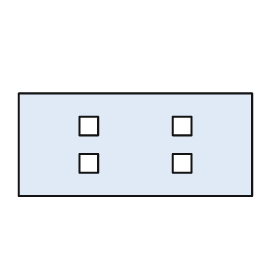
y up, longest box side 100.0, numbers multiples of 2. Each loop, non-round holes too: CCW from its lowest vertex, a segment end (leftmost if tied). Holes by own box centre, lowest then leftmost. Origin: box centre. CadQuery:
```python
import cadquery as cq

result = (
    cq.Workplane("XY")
    .moveTo(-50.0, -22.0)
    .lineTo(50.0, -22.0)
    .lineTo(50.0, 22.0)
    .lineTo(-50.0, 22.0)
    .close()
    .moveTo(-24.0, -12.0)
    .lineTo(-16.0, -12.0)
    .lineTo(-16.0, -4.0)
    .lineTo(-24.0, -4.0)
    .close()
    .moveTo(16.0, -12.0)
    .lineTo(24.0, -12.0)
    .lineTo(24.0, -4.0)
    .lineTo(16.0, -4.0)
    .close()
    .moveTo(-24.0, 4.0)
    .lineTo(-16.0, 4.0)
    .lineTo(-16.0, 12.0)
    .lineTo(-24.0, 12.0)
    .close()
    .moveTo(16.0, 4.0)
    .lineTo(24.0, 4.0)
    .lineTo(24.0, 12.0)
    .lineTo(16.0, 12.0)
    .close()
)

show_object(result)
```